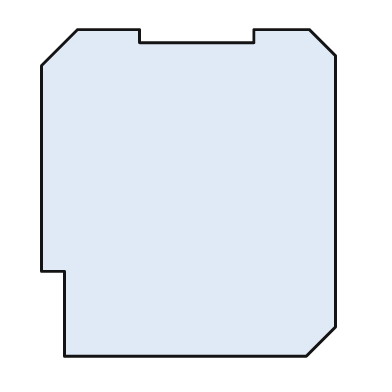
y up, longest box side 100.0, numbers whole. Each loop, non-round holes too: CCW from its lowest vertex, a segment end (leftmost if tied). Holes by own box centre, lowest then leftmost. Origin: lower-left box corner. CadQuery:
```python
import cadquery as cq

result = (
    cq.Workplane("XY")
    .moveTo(7.0, 0.0)
    .lineTo(81.0, 0.0)
    .lineTo(90.0, 9.0)
    .lineTo(90.0, 92.0)
    .lineTo(82.0, 100.0)
    .lineTo(65.0, 100.0)
    .lineTo(65.0, 96.0)
    .lineTo(30.0, 96.0)
    .lineTo(30.0, 100.0)
    .lineTo(11.0, 100.0)
    .lineTo(0.0, 89.0)
    .lineTo(0.0, 26.0)
    .lineTo(7.0, 26.0)
    .close()
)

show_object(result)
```